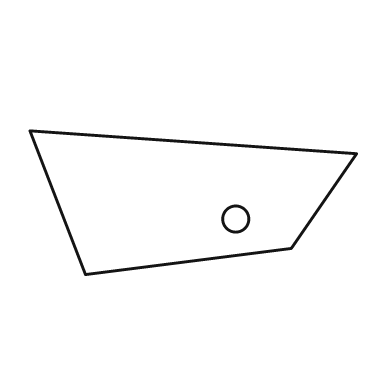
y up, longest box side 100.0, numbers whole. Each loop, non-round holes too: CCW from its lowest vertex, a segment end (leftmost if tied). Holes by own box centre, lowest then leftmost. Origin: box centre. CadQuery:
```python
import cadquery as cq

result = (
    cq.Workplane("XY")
    .moveTo(-33.0, -22.0)
    .lineTo(30.0, -14.0)
    .lineTo(50.0, 15.0)
    .lineTo(-50.0, 22.0)
    .close()
    .moveTo(13.0, -5.0)
    .circle(4.0)
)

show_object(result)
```